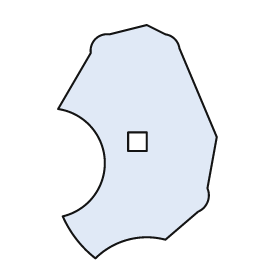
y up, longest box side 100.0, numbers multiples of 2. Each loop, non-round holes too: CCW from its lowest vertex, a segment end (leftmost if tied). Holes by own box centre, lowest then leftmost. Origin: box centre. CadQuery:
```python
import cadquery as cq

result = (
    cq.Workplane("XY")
    .moveTo(-18.0, -50.0)
    .threePointArc((-4.0, -42.0), (12.0, -42.0))
    .lineTo(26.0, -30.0)
    .threePointArc((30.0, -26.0), (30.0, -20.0))
    .lineTo(34.0, 2.0)
    .lineTo(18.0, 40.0)
    .threePointArc((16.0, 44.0), (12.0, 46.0))
    .lineTo(4.0, 50.0)
    .lineTo(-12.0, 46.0)
    .threePointArc((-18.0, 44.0), (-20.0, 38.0))
    .lineTo(-34.0, 14.0)
    .threePointArc((-14.0, -8.0), (-32.0, -32.0))
    .threePointArc((-26.0, -42.0), (-18.0, -50.0))
    .close()
    .moveTo(-4.0, -4.0)
    .lineTo(4.0, -4.0)
    .lineTo(4.0, 4.0)
    .lineTo(-4.0, 4.0)
    .close()
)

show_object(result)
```